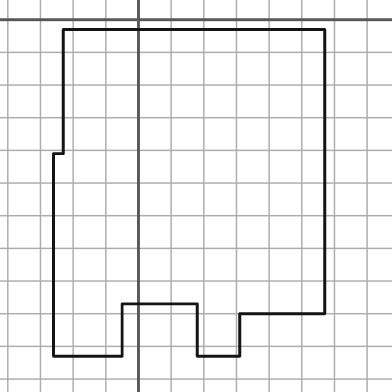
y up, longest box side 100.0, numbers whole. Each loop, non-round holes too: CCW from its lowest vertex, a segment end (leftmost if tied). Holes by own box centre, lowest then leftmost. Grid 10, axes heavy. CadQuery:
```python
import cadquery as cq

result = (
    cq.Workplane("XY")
    .moveTo(-26.0, -103.0)
    .lineTo(-5.0, -103.0)
    .lineTo(-5.0, -87.0)
    .lineTo(18.0, -87.0)
    .lineTo(18.0, -103.0)
    .lineTo(31.0, -103.0)
    .lineTo(31.0, -90.0)
    .lineTo(57.0, -90.0)
    .lineTo(57.0, -3.0)
    .lineTo(-23.0, -3.0)
    .lineTo(-23.0, -41.0)
    .lineTo(-26.0, -41.0)
    .close()
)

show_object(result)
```